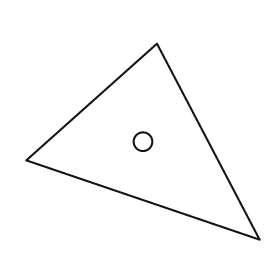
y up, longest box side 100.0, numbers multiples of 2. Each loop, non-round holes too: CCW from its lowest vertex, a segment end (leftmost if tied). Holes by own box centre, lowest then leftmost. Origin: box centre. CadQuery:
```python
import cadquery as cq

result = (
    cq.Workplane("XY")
    .moveTo(50.0, -42.0)
    .lineTo(6.0, 42.0)
    .lineTo(-50.0, -8.0)
    .close()
    .moveTo(0.0, 0.0)
    .circle(4.0)
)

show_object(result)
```